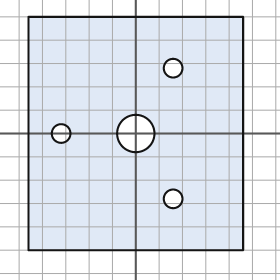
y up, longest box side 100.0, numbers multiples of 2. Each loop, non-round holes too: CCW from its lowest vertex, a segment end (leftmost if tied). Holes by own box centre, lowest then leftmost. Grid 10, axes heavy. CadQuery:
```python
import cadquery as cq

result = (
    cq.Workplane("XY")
    .moveTo(-46.0, -50.0)
    .lineTo(46.0, -50.0)
    .lineTo(46.0, 50.0)
    .lineTo(-46.0, 50.0)
    .close()
    .moveTo(16.0, -28.0)
    .circle(4.0)
    .moveTo(-32.0, 0.0)
    .circle(4.0)
    .moveTo(0.0, 0.0)
    .circle(8.0)
    .moveTo(16.0, 28.0)
    .circle(4.0)
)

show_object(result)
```